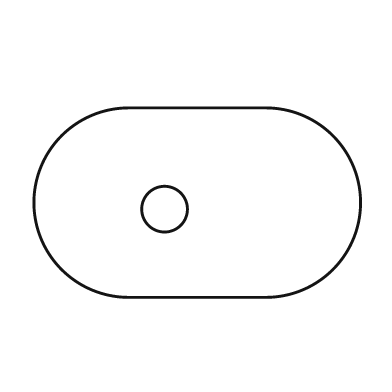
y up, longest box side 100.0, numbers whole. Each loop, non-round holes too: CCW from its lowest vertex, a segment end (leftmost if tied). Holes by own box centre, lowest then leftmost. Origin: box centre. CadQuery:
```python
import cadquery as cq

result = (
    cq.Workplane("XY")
    .moveTo(-21.0, -29.0)
    .lineTo(21.0, -29.0)
    .threePointArc((50.0, 0.0), (21.0, 29.0))
    .lineTo(-21.0, 29.0)
    .threePointArc((-50.0, 0.0), (-21.0, -29.0))
    .close()
    .moveTo(-10.0, -2.0)
    .circle(7.0)
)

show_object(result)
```